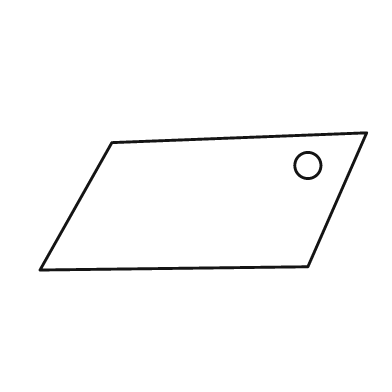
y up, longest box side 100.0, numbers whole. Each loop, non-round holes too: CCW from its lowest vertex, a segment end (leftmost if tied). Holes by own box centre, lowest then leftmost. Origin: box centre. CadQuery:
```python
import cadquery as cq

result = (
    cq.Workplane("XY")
    .moveTo(-50.0, -21.0)
    .lineTo(32.0, -20.0)
    .lineTo(50.0, 21.0)
    .lineTo(-28.0, 18.0)
    .close()
    .moveTo(32.0, 11.0)
    .circle(4.0)
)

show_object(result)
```